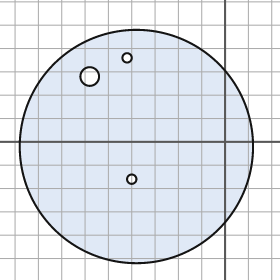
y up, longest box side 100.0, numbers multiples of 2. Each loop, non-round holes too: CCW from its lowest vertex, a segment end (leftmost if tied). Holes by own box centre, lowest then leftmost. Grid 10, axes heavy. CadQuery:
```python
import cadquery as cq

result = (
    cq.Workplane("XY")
    .moveTo(-38.0, -2.0)
    .circle(50.0)
    .moveTo(-40.0, -16.0)
    .circle(2.0)
    .moveTo(-58.0, 28.0)
    .circle(4.0)
    .moveTo(-42.0, 36.0)
    .circle(2.0)
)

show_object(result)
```